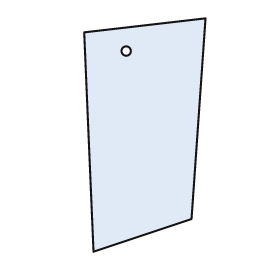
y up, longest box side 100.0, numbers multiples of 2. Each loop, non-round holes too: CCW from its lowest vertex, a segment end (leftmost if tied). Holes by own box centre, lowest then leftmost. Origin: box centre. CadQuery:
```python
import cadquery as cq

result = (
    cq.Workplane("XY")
    .moveTo(-22.0, -50.0)
    .lineTo(20.0, -36.0)
    .lineTo(26.0, 50.0)
    .lineTo(-26.0, 44.0)
    .close()
    .moveTo(-8.0, 36.0)
    .circle(2.0)
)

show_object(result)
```